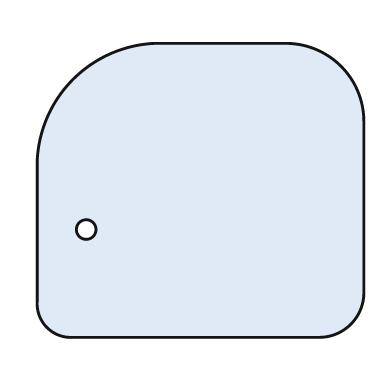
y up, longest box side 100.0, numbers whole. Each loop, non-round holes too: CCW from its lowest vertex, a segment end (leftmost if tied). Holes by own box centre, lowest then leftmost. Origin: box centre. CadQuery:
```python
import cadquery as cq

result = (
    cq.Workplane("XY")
    .moveTo(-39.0, -45.0)
    .lineTo(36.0, -45.0)
    .threePointArc((46.0, -41.0), (50.0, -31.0))
    .lineTo(50.0, 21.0)
    .threePointArc((43.0, 38.0), (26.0, 45.0))
    .lineTo(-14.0, 45.0)
    .threePointArc((-39.0, 34.0), (-50.0, 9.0))
    .lineTo(-50.0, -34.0)
    .threePointArc((-47.0, -42.0), (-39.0, -45.0))
    .close()
    .moveTo(-35.0, -12.0)
    .circle(3.0)
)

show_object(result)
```